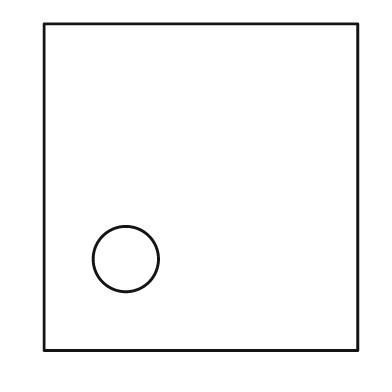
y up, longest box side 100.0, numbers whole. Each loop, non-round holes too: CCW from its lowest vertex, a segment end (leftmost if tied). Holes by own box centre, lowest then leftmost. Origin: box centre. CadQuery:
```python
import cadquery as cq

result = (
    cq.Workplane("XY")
    .moveTo(-48.0, -50.0)
    .lineTo(48.0, -50.0)
    .lineTo(48.0, 50.0)
    .lineTo(-48.0, 50.0)
    .close()
    .moveTo(-23.0, -22.0)
    .circle(10.0)
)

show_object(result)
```